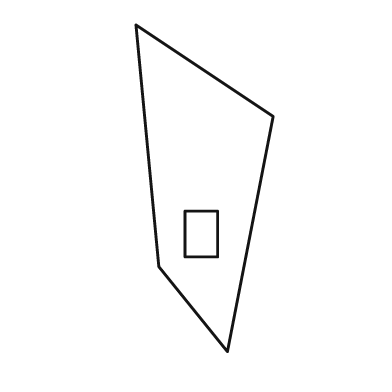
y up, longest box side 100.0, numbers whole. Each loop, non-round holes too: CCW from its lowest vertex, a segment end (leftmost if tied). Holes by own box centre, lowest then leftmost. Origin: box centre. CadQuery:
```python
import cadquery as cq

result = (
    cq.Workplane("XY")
    .moveTo(7.0, -50.0)
    .lineTo(21.0, 22.0)
    .lineTo(-21.0, 50.0)
    .lineTo(-14.0, -24.0)
    .close()
    .moveTo(-6.0, -21.0)
    .lineTo(4.0, -21.0)
    .lineTo(4.0, -7.0)
    .lineTo(-6.0, -7.0)
    .close()
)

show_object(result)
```